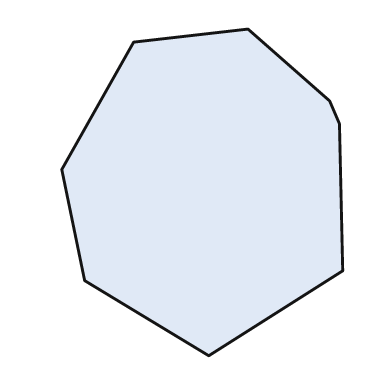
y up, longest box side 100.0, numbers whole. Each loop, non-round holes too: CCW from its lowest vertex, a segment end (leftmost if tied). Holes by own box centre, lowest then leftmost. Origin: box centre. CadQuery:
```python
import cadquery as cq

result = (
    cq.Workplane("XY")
    .moveTo(2.0, -50.0)
    .lineTo(43.0, -24.0)
    .lineTo(42.0, 21.0)
    .lineTo(39.0, 28.0)
    .lineTo(14.0, 50.0)
    .lineTo(-21.0, 46.0)
    .lineTo(-43.0, 7.0)
    .lineTo(-36.0, -27.0)
    .close()
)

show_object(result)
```